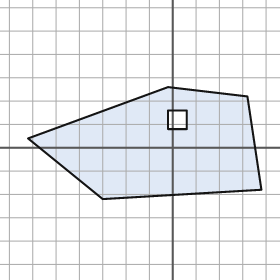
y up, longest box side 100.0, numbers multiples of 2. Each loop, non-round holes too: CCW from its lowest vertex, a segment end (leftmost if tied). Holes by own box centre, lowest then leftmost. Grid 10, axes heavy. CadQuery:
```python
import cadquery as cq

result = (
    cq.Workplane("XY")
    .moveTo(-30.0, -22.0)
    .lineTo(38.0, -18.0)
    .lineTo(32.0, 22.0)
    .lineTo(-2.0, 26.0)
    .lineTo(-62.0, 4.0)
    .close()
    .moveTo(-2.0, 8.0)
    .lineTo(6.0, 8.0)
    .lineTo(6.0, 16.0)
    .lineTo(-2.0, 16.0)
    .close()
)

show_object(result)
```